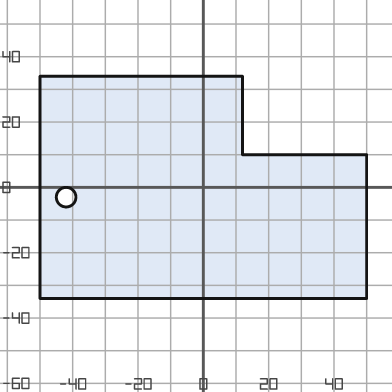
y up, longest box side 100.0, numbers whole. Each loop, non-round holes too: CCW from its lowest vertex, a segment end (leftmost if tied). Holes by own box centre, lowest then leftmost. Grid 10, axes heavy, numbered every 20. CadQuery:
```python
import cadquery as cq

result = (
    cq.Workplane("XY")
    .moveTo(-50.0, -34.0)
    .lineTo(50.0, -34.0)
    .lineTo(50.0, 10.0)
    .lineTo(12.0, 10.0)
    .lineTo(12.0, 34.0)
    .lineTo(-50.0, 34.0)
    .close()
    .moveTo(-42.0, -3.0)
    .circle(3.0)
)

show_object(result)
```